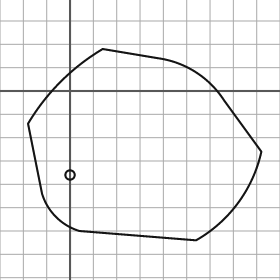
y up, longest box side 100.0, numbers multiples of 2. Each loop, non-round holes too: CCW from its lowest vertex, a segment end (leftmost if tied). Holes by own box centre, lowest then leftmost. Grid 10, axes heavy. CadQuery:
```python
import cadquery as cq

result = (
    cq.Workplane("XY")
    .moveTo(54.0, -64.0)
    .threePointArc((72.0, -48.0), (82.0, -26.0))
    .lineTo(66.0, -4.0)
    .threePointArc((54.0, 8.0), (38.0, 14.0))
    .lineTo(14.0, 18.0)
    .threePointArc((-4.0, 4.0), (-18.0, -14.0))
    .lineTo(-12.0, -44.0)
    .threePointArc((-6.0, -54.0), (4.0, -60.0))
    .close()
    .moveTo(0.0, -36.0)
    .circle(2.0)
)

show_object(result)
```